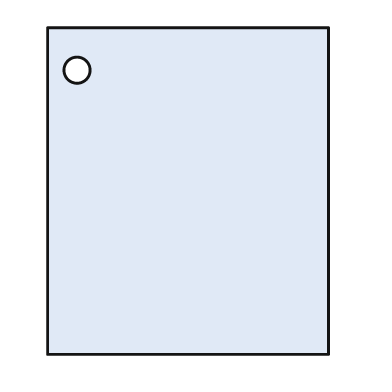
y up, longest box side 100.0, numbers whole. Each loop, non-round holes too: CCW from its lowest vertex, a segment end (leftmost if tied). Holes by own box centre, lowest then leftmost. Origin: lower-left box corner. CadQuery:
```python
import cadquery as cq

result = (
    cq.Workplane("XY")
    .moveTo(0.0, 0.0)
    .lineTo(86.0, 0.0)
    .lineTo(86.0, 100.0)
    .lineTo(0.0, 100.0)
    .close()
    .moveTo(9.0, 87.0)
    .circle(4.0)
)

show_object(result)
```